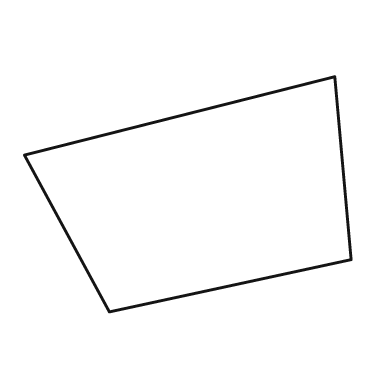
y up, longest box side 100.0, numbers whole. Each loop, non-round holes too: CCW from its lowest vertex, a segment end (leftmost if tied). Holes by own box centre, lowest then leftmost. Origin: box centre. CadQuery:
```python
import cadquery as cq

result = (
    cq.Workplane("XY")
    .moveTo(-24.0, -36.0)
    .lineTo(50.0, -20.0)
    .lineTo(45.0, 36.0)
    .lineTo(-50.0, 12.0)
    .close()
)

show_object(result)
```